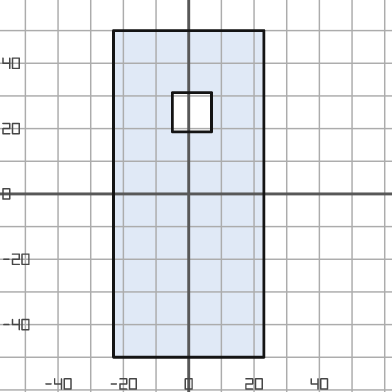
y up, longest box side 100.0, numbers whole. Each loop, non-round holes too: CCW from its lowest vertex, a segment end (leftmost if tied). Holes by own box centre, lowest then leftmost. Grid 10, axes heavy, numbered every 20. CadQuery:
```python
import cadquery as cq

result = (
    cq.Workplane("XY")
    .moveTo(-23.0, -50.0)
    .lineTo(23.0, -50.0)
    .lineTo(23.0, 50.0)
    .lineTo(-23.0, 50.0)
    .close()
    .moveTo(-5.0, 19.0)
    .lineTo(7.0, 19.0)
    .lineTo(7.0, 31.0)
    .lineTo(-5.0, 31.0)
    .close()
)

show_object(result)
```